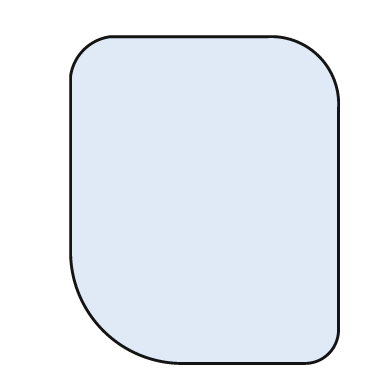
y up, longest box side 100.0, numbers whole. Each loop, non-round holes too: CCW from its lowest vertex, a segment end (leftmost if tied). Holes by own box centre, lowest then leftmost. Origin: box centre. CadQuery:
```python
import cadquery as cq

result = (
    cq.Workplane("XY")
    .moveTo(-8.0, -50.0)
    .lineTo(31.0, -50.0)
    .threePointArc((38.0, -47.0), (41.0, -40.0))
    .lineTo(41.0, 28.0)
    .threePointArc((35.0, 44.0), (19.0, 50.0))
    .lineTo(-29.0, 50.0)
    .threePointArc((-37.0, 46.0), (-41.0, 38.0))
    .lineTo(-41.0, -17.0)
    .threePointArc((-31.0, -40.0), (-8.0, -50.0))
    .close()
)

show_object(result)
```